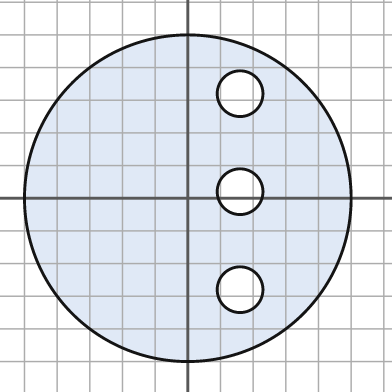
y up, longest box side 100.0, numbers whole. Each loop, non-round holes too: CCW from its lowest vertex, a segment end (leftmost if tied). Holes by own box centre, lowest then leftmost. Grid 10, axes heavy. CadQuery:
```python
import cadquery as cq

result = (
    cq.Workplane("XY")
    .moveTo(0.0, 0.0)
    .circle(50.0)
    .moveTo(16.0, -28.0)
    .circle(7.0)
    .moveTo(16.0, 2.0)
    .circle(7.0)
    .moveTo(16.0, 32.0)
    .circle(7.0)
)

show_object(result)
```